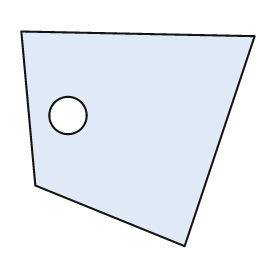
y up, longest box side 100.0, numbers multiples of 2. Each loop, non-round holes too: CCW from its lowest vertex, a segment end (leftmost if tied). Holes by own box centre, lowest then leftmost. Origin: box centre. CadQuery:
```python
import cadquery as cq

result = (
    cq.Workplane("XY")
    .moveTo(20.0, -46.0)
    .lineTo(50.0, 44.0)
    .lineTo(-50.0, 46.0)
    .lineTo(-44.0, -20.0)
    .close()
    .moveTo(-30.0, 10.0)
    .circle(8.0)
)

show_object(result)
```